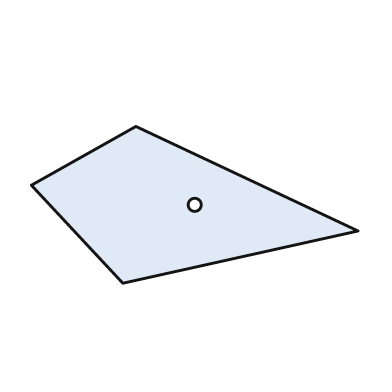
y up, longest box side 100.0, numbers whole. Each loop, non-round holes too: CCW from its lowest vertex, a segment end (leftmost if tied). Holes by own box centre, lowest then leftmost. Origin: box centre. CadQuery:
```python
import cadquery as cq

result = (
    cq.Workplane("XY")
    .moveTo(-22.0, -24.0)
    .lineTo(50.0, -8.0)
    .lineTo(-18.0, 24.0)
    .lineTo(-50.0, 6.0)
    .close()
    .moveTo(0.0, 0.0)
    .circle(2.0)
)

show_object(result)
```